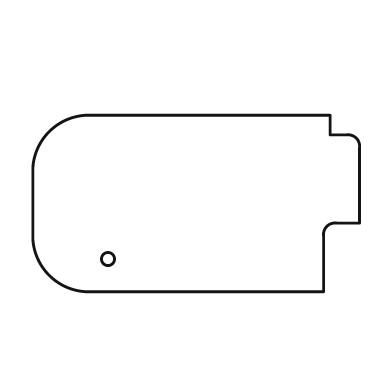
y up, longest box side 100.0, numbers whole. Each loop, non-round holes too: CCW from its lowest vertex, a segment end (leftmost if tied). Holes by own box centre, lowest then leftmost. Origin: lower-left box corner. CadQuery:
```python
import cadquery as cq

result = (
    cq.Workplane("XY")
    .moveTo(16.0, 0.0)
    .lineTo(89.0, 0.0)
    .lineTo(89.0, 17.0)
    .threePointArc((90.0, 20.0), (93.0, 21.0))
    .lineTo(100.0, 21.0)
    .lineTo(100.0, 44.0)
    .threePointArc((99.0, 47.0), (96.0, 48.0))
    .lineTo(91.0, 48.0)
    .lineTo(91.0, 54.0)
    .lineTo(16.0, 54.0)
    .threePointArc((5.0, 49.0), (0.0, 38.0))
    .lineTo(0.0, 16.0)
    .threePointArc((5.0, 5.0), (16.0, 0.0))
    .close()
    .moveTo(23.0, 10.0)
    .circle(2.0)
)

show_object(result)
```